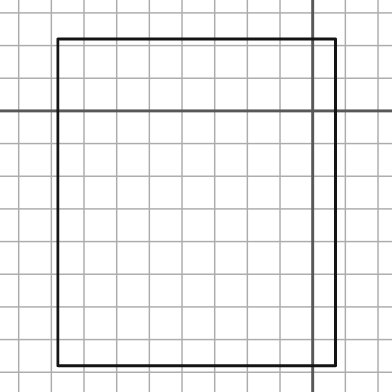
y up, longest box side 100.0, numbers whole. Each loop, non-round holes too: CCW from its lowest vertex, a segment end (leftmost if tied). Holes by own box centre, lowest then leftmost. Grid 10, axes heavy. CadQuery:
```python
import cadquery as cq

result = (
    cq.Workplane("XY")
    .moveTo(-78.0, -78.0)
    .lineTo(7.0, -78.0)
    .lineTo(7.0, 22.0)
    .lineTo(-78.0, 22.0)
    .close()
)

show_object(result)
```